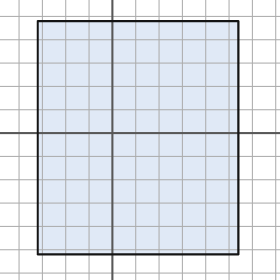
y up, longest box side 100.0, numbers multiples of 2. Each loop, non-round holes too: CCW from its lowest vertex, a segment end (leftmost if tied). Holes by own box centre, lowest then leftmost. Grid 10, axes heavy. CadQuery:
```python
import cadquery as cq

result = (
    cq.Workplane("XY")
    .moveTo(-32.0, -52.0)
    .lineTo(54.0, -52.0)
    .lineTo(54.0, 48.0)
    .lineTo(-32.0, 48.0)
    .close()
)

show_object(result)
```